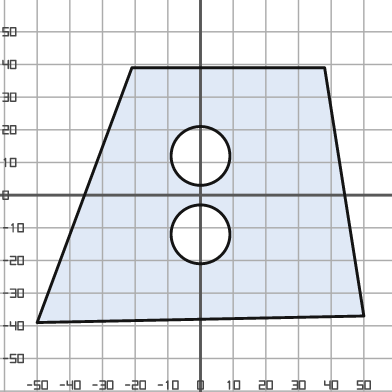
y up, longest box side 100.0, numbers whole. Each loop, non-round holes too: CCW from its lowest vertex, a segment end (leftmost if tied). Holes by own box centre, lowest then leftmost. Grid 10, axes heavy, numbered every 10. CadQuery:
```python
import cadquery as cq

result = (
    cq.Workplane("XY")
    .moveTo(-50.0, -39.0)
    .lineTo(50.0, -37.0)
    .lineTo(38.0, 39.0)
    .lineTo(-21.0, 39.0)
    .close()
    .moveTo(0.0, -12.0)
    .circle(9.0)
    .moveTo(0.0, 12.0)
    .circle(9.0)
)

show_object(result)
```